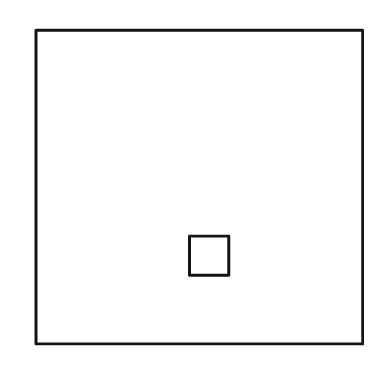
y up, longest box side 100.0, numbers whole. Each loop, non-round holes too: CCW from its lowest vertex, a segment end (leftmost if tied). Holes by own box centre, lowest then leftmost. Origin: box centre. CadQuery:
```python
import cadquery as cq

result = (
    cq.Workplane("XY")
    .moveTo(-50.0, -48.0)
    .lineTo(50.0, -48.0)
    .lineTo(50.0, 48.0)
    .lineTo(-50.0, 48.0)
    .close()
    .moveTo(-3.0, -27.0)
    .lineTo(9.0, -27.0)
    .lineTo(9.0, -15.0)
    .lineTo(-3.0, -15.0)
    .close()
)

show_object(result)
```